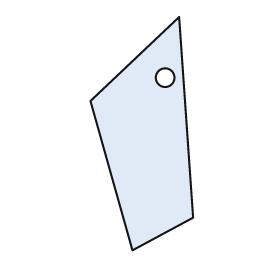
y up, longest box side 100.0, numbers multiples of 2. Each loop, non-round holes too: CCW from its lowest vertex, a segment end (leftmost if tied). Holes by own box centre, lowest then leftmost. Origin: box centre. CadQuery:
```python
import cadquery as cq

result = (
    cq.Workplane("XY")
    .moveTo(-4.0, -50.0)
    .lineTo(22.0, -36.0)
    .lineTo(16.0, 50.0)
    .lineTo(-22.0, 14.0)
    .close()
    .moveTo(10.0, 24.0)
    .circle(4.0)
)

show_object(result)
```